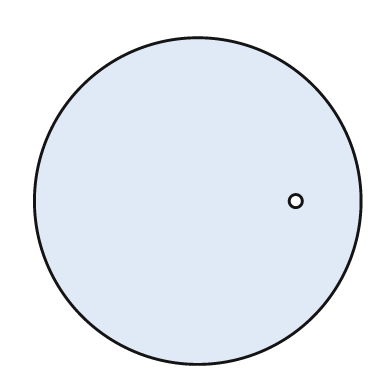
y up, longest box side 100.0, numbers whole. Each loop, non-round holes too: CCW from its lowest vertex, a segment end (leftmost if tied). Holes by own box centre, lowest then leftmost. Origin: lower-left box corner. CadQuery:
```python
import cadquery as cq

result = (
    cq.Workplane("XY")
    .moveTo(50.0, 50.0)
    .circle(50.0)
    .moveTo(80.0, 50.0)
    .circle(2.0)
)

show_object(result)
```